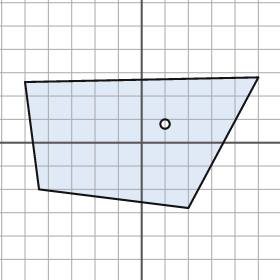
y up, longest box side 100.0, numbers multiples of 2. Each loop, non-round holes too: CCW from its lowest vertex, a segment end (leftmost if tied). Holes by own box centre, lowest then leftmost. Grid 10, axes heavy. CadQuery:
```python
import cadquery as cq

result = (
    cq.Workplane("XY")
    .moveTo(20.0, -28.0)
    .lineTo(50.0, 28.0)
    .lineTo(-50.0, 26.0)
    .lineTo(-44.0, -20.0)
    .close()
    .moveTo(10.0, 8.0)
    .circle(2.0)
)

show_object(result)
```